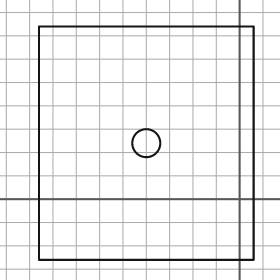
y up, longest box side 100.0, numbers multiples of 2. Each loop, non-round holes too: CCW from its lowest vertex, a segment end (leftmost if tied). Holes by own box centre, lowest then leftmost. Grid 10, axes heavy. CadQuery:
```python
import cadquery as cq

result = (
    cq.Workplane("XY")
    .moveTo(-86.0, -26.0)
    .lineTo(6.0, -26.0)
    .lineTo(6.0, 74.0)
    .lineTo(-86.0, 74.0)
    .close()
    .moveTo(-40.0, 24.0)
    .circle(6.0)
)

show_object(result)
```